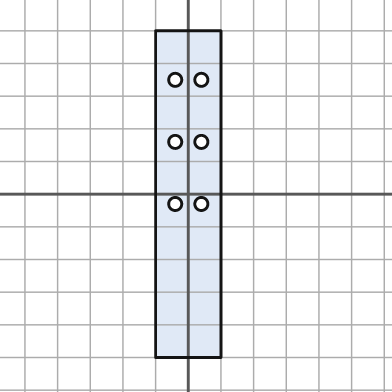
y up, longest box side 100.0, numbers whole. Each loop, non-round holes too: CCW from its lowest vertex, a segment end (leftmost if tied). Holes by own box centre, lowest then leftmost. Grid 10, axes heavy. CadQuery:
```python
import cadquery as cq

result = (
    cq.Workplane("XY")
    .moveTo(-10.0, -50.0)
    .lineTo(10.0, -50.0)
    .lineTo(10.0, 50.0)
    .lineTo(-10.0, 50.0)
    .close()
    .moveTo(-4.0, -3.0)
    .circle(2.0)
    .moveTo(4.0, -3.0)
    .circle(2.0)
    .moveTo(-4.0, 16.0)
    .circle(2.0)
    .moveTo(4.0, 16.0)
    .circle(2.0)
    .moveTo(-4.0, 35.0)
    .circle(2.0)
    .moveTo(4.0, 35.0)
    .circle(2.0)
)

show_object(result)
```